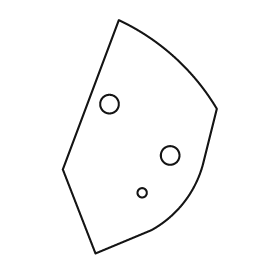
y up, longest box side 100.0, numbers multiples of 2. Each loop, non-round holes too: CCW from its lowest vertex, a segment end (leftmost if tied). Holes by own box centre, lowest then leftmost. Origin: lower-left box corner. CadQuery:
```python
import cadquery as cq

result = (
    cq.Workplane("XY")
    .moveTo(14.0, 0.0)
    .lineTo(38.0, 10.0)
    .threePointArc((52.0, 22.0), (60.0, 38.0))
    .lineTo(66.0, 62.0)
    .threePointArc((48.0, 84.0), (24.0, 100.0))
    .lineTo(0.0, 36.0)
    .close()
    .moveTo(34.0, 26.0)
    .circle(2.0)
    .moveTo(46.0, 42.0)
    .circle(4.0)
    .moveTo(20.0, 64.0)
    .circle(4.0)
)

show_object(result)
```